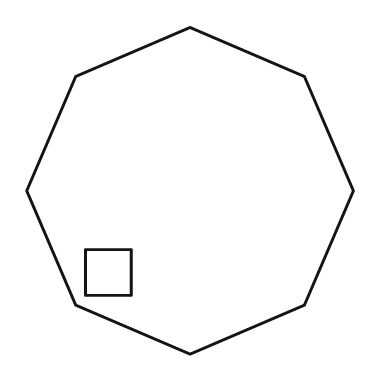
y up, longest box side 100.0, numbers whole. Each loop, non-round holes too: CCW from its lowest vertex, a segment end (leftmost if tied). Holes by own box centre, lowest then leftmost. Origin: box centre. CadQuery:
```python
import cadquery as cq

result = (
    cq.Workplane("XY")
    .moveTo(0.0, -50.0)
    .lineTo(35.0, -35.0)
    .lineTo(50.0, 0.0)
    .lineTo(35.0, 35.0)
    .lineTo(0.0, 50.0)
    .lineTo(-35.0, 35.0)
    .lineTo(-50.0, 0.0)
    .lineTo(-35.0, -35.0)
    .close()
    .moveTo(-32.0, -32.0)
    .lineTo(-18.0, -32.0)
    .lineTo(-18.0, -18.0)
    .lineTo(-32.0, -18.0)
    .close()
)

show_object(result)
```